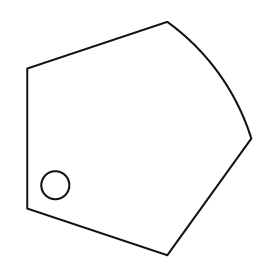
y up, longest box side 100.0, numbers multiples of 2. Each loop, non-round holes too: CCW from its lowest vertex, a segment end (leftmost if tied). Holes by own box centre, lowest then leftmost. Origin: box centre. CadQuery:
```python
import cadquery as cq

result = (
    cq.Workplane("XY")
    .moveTo(12.0, -50.0)
    .lineTo(48.0, 0.0)
    .threePointArc((34.0, 28.0), (12.0, 50.0))
    .lineTo(-48.0, 30.0)
    .lineTo(-48.0, -30.0)
    .close()
    .moveTo(-36.0, -20.0)
    .circle(6.0)
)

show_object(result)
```